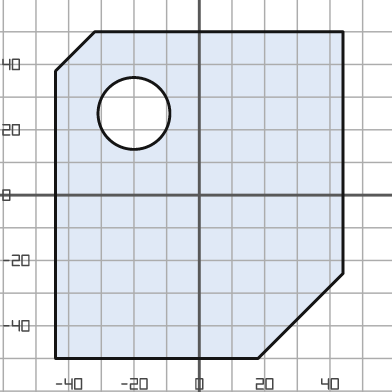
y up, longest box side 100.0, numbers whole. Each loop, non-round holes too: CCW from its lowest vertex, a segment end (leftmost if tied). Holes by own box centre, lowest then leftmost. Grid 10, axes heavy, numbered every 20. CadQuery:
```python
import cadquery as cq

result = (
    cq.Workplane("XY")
    .moveTo(-44.0, -50.0)
    .lineTo(18.0, -50.0)
    .lineTo(44.0, -24.0)
    .lineTo(44.0, 50.0)
    .lineTo(-32.0, 50.0)
    .lineTo(-44.0, 38.0)
    .close()
    .moveTo(-20.0, 25.0)
    .circle(11.0)
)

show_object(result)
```